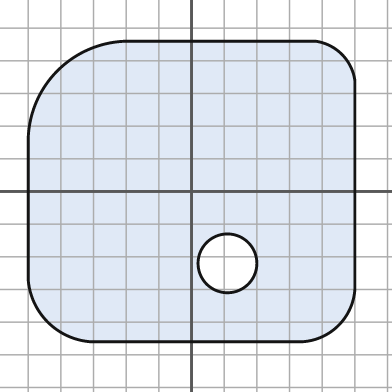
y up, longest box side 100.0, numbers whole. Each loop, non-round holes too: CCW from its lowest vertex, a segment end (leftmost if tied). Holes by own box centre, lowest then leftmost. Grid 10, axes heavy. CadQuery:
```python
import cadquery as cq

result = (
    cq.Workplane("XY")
    .moveTo(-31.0, -46.0)
    .lineTo(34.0, -46.0)
    .threePointArc((45.0, -41.0), (50.0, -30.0))
    .lineTo(50.0, 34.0)
    .threePointArc((46.0, 42.0), (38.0, 46.0))
    .lineTo(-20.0, 46.0)
    .threePointArc((-41.0, 37.0), (-50.0, 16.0))
    .lineTo(-50.0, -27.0)
    .threePointArc((-44.0, -40.0), (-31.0, -46.0))
    .close()
    .moveTo(11.0, -22.0)
    .circle(9.0)
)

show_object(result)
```